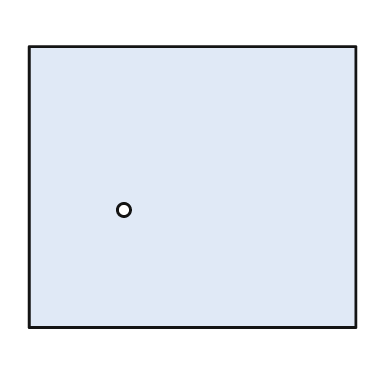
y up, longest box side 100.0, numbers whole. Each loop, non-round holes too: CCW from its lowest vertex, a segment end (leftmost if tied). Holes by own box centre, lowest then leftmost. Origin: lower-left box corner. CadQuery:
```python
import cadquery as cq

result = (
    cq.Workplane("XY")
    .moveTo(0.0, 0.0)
    .lineTo(100.0, 0.0)
    .lineTo(100.0, 86.0)
    .lineTo(0.0, 86.0)
    .close()
    .moveTo(29.0, 36.0)
    .circle(2.0)
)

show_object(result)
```